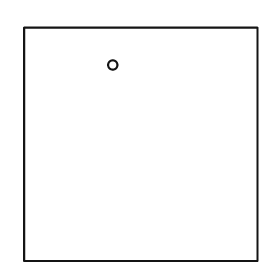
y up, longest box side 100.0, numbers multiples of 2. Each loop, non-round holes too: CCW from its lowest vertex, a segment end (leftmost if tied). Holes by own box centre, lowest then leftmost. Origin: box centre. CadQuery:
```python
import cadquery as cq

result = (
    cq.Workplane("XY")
    .moveTo(-50.0, -50.0)
    .lineTo(50.0, -50.0)
    .lineTo(50.0, 50.0)
    .lineTo(-50.0, 50.0)
    .close()
    .moveTo(-12.0, 34.0)
    .circle(2.0)
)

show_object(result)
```